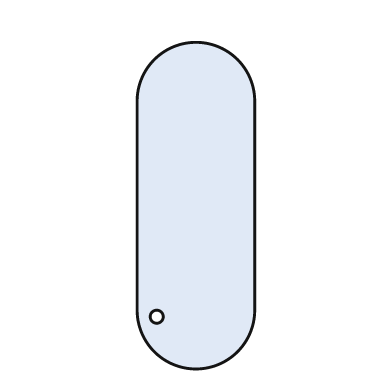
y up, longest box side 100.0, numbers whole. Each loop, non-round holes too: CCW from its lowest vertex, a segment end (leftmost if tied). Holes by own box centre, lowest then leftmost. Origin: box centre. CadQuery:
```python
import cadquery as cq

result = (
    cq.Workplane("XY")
    .moveTo(-18.0, -32.0)
    .threePointArc((0.0, -50.0), (18.0, -32.0))
    .lineTo(18.0, 32.0)
    .threePointArc((0.0, 50.0), (-18.0, 32.0))
    .close()
    .moveTo(-12.0, -34.0)
    .circle(2.0)
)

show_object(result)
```